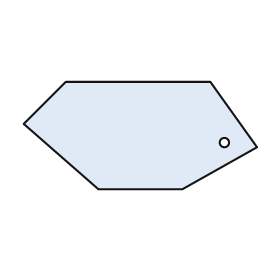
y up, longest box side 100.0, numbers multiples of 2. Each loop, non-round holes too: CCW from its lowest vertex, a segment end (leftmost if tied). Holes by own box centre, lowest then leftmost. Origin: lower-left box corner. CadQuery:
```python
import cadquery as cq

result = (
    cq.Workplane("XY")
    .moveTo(32.0, 0.0)
    .lineTo(68.0, 0.0)
    .lineTo(100.0, 18.0)
    .lineTo(80.0, 46.0)
    .lineTo(18.0, 46.0)
    .lineTo(0.0, 28.0)
    .close()
    .moveTo(86.0, 20.0)
    .circle(2.0)
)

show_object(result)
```